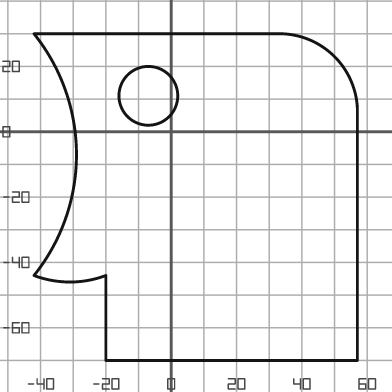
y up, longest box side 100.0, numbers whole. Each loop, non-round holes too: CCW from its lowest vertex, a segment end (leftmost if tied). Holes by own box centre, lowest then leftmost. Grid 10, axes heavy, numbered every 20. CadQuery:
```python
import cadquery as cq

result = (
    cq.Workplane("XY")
    .moveTo(-20.0, -70.0)
    .lineTo(57.0, -70.0)
    .lineTo(57.0, 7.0)
    .threePointArc((50.0, 23.0), (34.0, 30.0))
    .lineTo(-42.0, 30.0)
    .threePointArc((-29.0, -7.0), (-42.0, -44.0))
    .threePointArc((-31.0, -46.0), (-20.0, -44.0))
    .close()
    .moveTo(-7.0, 11.0)
    .circle(9.0)
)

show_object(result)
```